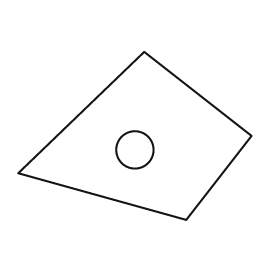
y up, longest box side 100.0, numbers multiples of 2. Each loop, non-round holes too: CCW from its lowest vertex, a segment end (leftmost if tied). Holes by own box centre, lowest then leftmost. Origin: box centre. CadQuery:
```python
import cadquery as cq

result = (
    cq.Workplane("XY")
    .moveTo(22.0, -36.0)
    .lineTo(50.0, 0.0)
    .lineTo(4.0, 36.0)
    .lineTo(-50.0, -16.0)
    .close()
    .moveTo(0.0, -6.0)
    .circle(8.0)
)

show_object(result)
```